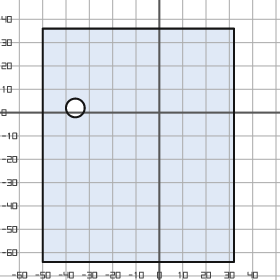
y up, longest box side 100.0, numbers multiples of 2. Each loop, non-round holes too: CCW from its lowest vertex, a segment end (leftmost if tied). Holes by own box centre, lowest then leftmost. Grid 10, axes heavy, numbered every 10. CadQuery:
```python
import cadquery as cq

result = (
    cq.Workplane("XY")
    .moveTo(-50.0, -64.0)
    .lineTo(32.0, -64.0)
    .lineTo(32.0, 36.0)
    .lineTo(-50.0, 36.0)
    .close()
    .moveTo(-36.0, 2.0)
    .circle(4.0)
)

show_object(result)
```